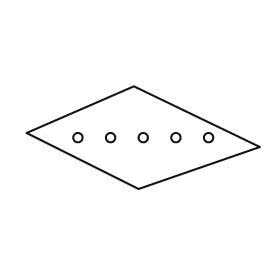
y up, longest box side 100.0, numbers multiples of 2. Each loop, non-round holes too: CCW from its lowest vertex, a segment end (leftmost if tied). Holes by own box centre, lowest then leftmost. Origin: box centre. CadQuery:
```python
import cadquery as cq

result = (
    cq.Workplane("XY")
    .moveTo(-2.0, -22.0)
    .lineTo(50.0, -4.0)
    .lineTo(-4.0, 22.0)
    .lineTo(-50.0, 2.0)
    .close()
    .moveTo(-28.0, 0.0)
    .circle(2.0)
    .moveTo(-14.0, 0.0)
    .circle(2.0)
    .moveTo(0.0, 0.0)
    .circle(2.0)
    .moveTo(14.0, 0.0)
    .circle(2.0)
    .moveTo(28.0, 0.0)
    .circle(2.0)
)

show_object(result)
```